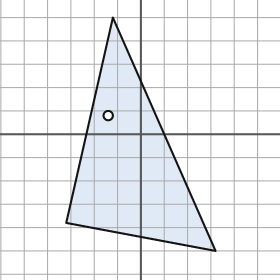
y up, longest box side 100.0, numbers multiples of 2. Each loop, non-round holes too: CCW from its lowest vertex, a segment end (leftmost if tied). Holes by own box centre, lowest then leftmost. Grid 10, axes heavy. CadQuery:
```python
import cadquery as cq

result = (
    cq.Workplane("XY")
    .moveTo(32.0, -50.0)
    .lineTo(-12.0, 50.0)
    .lineTo(-32.0, -38.0)
    .close()
    .moveTo(-14.0, 8.0)
    .circle(2.0)
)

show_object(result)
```